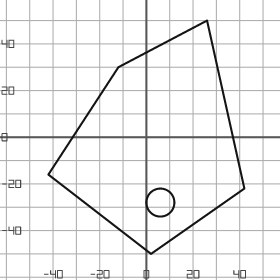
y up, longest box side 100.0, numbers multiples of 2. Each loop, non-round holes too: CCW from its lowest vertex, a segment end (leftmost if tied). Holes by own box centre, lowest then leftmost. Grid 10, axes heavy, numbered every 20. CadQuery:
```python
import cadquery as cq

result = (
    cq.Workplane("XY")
    .moveTo(2.0, -50.0)
    .lineTo(42.0, -22.0)
    .lineTo(26.0, 50.0)
    .lineTo(-12.0, 30.0)
    .lineTo(-42.0, -16.0)
    .close()
    .moveTo(6.0, -28.0)
    .circle(6.0)
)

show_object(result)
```